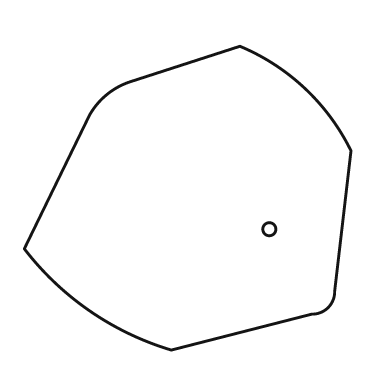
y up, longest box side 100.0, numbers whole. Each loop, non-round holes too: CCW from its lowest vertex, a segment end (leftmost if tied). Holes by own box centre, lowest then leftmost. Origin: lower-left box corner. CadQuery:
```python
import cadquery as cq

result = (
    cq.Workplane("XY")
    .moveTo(45.0, 0.0)
    .lineTo(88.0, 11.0)
    .threePointArc((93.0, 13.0), (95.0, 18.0))
    .lineTo(100.0, 61.0)
    .threePointArc((86.0, 80.0), (66.0, 93.0))
    .lineTo(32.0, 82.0)
    .threePointArc((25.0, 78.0), (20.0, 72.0))
    .lineTo(0.0, 31.0)
    .threePointArc((20.0, 12.0), (45.0, 0.0))
    .close()
    .moveTo(75.0, 37.0)
    .circle(2.0)
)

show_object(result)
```